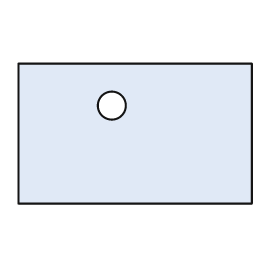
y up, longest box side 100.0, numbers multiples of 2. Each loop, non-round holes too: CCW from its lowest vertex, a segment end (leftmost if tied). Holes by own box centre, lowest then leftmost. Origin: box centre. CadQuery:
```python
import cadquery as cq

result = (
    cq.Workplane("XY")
    .moveTo(-50.0, -30.0)
    .lineTo(50.0, -30.0)
    .lineTo(50.0, 30.0)
    .lineTo(-50.0, 30.0)
    .close()
    .moveTo(-10.0, 12.0)
    .circle(6.0)
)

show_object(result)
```